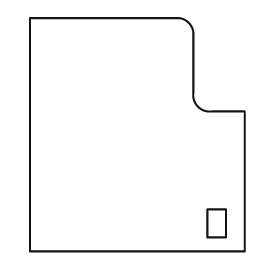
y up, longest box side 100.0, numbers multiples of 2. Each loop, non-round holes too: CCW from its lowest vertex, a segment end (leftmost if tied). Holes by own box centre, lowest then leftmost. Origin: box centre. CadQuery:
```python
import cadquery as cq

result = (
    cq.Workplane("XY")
    .moveTo(-46.0, -50.0)
    .lineTo(46.0, -50.0)
    .lineTo(46.0, 10.0)
    .lineTo(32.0, 10.0)
    .threePointArc((26.0, 12.0), (24.0, 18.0))
    .lineTo(24.0, 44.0)
    .threePointArc((22.0, 48.0), (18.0, 50.0))
    .lineTo(-46.0, 50.0)
    .close()
    .moveTo(30.0, -44.0)
    .lineTo(38.0, -44.0)
    .lineTo(38.0, -32.0)
    .lineTo(30.0, -32.0)
    .close()
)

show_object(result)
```